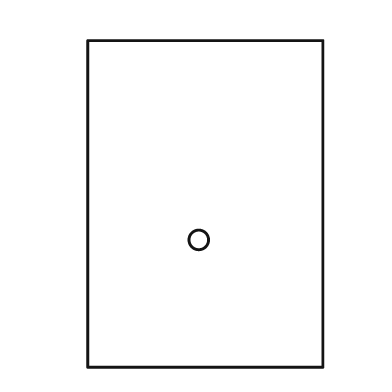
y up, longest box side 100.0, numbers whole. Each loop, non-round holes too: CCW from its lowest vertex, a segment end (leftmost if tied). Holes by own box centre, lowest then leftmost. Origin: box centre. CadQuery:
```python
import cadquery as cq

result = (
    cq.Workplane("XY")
    .moveTo(-36.0, -50.0)
    .lineTo(36.0, -50.0)
    .lineTo(36.0, 50.0)
    .lineTo(-36.0, 50.0)
    .close()
    .moveTo(-2.0, -11.0)
    .circle(3.0)
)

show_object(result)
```